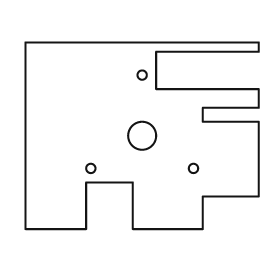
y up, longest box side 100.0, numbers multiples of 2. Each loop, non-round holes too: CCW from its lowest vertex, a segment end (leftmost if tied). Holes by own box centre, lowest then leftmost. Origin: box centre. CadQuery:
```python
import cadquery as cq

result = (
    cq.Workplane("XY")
    .moveTo(-50.0, -40.0)
    .lineTo(-24.0, -40.0)
    .lineTo(-24.0, -20.0)
    .lineTo(-4.0, -20.0)
    .lineTo(-4.0, -40.0)
    .lineTo(26.0, -40.0)
    .lineTo(26.0, -26.0)
    .lineTo(50.0, -26.0)
    .lineTo(50.0, 6.0)
    .lineTo(26.0, 6.0)
    .lineTo(26.0, 12.0)
    .lineTo(50.0, 12.0)
    .lineTo(50.0, 20.0)
    .lineTo(6.0, 20.0)
    .lineTo(6.0, 36.0)
    .lineTo(50.0, 36.0)
    .lineTo(50.0, 40.0)
    .lineTo(-50.0, 40.0)
    .close()
    .moveTo(-22.0, -14.0)
    .circle(2.0)
    .moveTo(22.0, -14.0)
    .circle(2.0)
    .moveTo(0.0, 0.0)
    .circle(6.0)
    .moveTo(0.0, 26.0)
    .circle(2.0)
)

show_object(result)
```